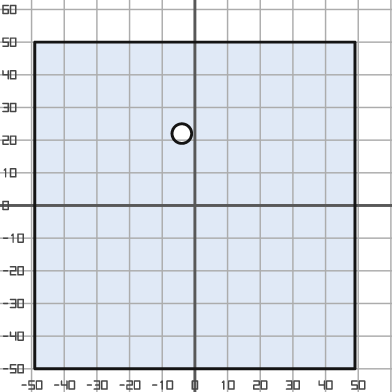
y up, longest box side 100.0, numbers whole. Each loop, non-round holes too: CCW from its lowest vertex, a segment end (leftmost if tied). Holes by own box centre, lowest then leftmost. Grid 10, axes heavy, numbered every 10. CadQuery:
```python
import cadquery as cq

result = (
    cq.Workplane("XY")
    .moveTo(-49.0, -50.0)
    .lineTo(49.0, -50.0)
    .lineTo(49.0, 50.0)
    .lineTo(-49.0, 50.0)
    .close()
    .moveTo(-4.0, 22.0)
    .circle(3.0)
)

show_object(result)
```